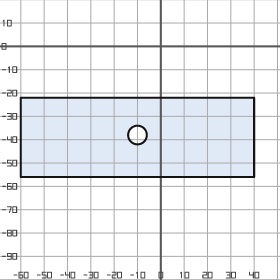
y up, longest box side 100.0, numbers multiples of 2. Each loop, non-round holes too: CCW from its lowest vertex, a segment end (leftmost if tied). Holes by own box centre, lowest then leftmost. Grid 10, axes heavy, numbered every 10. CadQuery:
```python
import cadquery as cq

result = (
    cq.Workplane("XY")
    .moveTo(-60.0, -56.0)
    .lineTo(40.0, -56.0)
    .lineTo(40.0, -22.0)
    .lineTo(-60.0, -22.0)
    .close()
    .moveTo(-10.0, -38.0)
    .circle(4.0)
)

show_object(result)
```